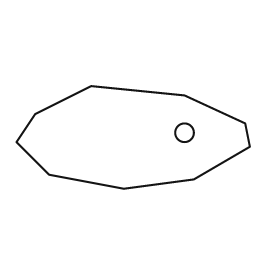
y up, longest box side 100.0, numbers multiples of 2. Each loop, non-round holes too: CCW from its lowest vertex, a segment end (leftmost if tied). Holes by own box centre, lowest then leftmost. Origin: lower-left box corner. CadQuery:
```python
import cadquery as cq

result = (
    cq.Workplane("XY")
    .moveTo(46.0, 0.0)
    .lineTo(76.0, 4.0)
    .lineTo(100.0, 18.0)
    .lineTo(98.0, 28.0)
    .lineTo(72.0, 40.0)
    .lineTo(32.0, 44.0)
    .lineTo(8.0, 32.0)
    .lineTo(0.0, 20.0)
    .lineTo(14.0, 6.0)
    .close()
    .moveTo(72.0, 24.0)
    .circle(4.0)
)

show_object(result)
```